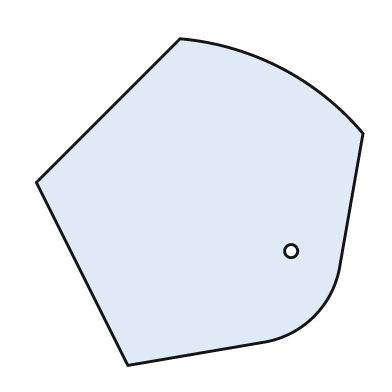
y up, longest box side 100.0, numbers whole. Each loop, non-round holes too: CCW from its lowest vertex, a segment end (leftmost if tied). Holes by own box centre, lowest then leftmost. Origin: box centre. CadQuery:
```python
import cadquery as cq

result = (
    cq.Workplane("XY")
    .moveTo(-22.0, -50.0)
    .lineTo(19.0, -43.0)
    .threePointArc((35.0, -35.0), (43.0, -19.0))
    .lineTo(50.0, 21.0)
    .threePointArc((25.0, 41.0), (-6.0, 50.0))
    .lineTo(-50.0, 6.0)
    .close()
    .moveTo(28.0, -15.0)
    .circle(2.0)
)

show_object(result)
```